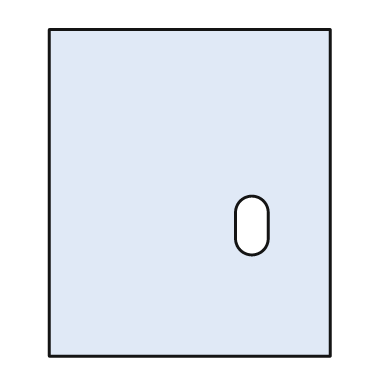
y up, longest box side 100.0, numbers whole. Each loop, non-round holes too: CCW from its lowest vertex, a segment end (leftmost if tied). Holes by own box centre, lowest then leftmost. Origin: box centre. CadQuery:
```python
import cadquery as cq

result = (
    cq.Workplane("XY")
    .moveTo(-43.0, -50.0)
    .lineTo(43.0, -50.0)
    .lineTo(43.0, 50.0)
    .lineTo(-43.0, 50.0)
    .close()
    .moveTo(14.0, -14.0)
    .threePointArc((19.0, -19.0), (24.0, -14.0))
    .lineTo(24.0, -6.0)
    .threePointArc((19.0, -1.0), (14.0, -6.0))
    .close()
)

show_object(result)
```